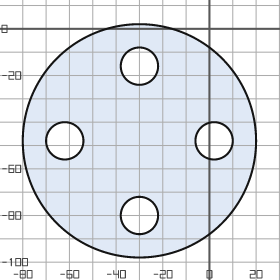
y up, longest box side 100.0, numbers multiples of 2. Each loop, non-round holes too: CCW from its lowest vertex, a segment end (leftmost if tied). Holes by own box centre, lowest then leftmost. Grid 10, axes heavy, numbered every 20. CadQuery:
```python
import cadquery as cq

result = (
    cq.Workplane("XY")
    .moveTo(-30.0, -48.0)
    .circle(50.0)
    .moveTo(-30.0, -80.0)
    .circle(8.0)
    .moveTo(-62.0, -48.0)
    .circle(8.0)
    .moveTo(2.0, -48.0)
    .circle(8.0)
    .moveTo(-30.0, -16.0)
    .circle(8.0)
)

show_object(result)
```